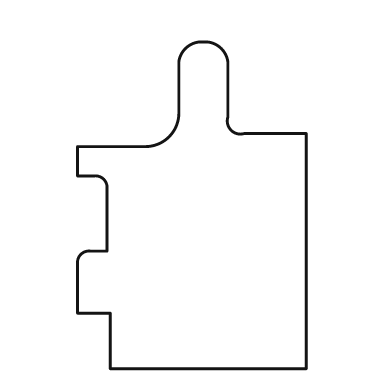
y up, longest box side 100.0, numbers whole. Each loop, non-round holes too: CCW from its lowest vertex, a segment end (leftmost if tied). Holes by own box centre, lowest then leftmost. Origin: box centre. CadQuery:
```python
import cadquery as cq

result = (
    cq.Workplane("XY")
    .moveTo(-25.0, -50.0)
    .lineTo(35.0, -50.0)
    .lineTo(35.0, 22.0)
    .lineTo(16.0, 22.0)
    .threePointArc((12.0, 23.0), (11.0, 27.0))
    .lineTo(11.0, 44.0)
    .threePointArc((9.0, 48.0), (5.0, 50.0))
    .lineTo(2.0, 50.0)
    .threePointArc((-2.0, 48.0), (-4.0, 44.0))
    .lineTo(-4.0, 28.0)
    .threePointArc((-7.0, 21.0), (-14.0, 18.0))
    .lineTo(-35.0, 18.0)
    .lineTo(-35.0, 9.0)
    .lineTo(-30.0, 9.0)
    .threePointArc((-27.0, 8.0), (-26.0, 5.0))
    .lineTo(-26.0, -14.0)
    .lineTo(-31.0, -14.0)
    .threePointArc((-34.0, -15.0), (-35.0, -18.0))
    .lineTo(-35.0, -33.0)
    .lineTo(-25.0, -33.0)
    .close()
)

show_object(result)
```